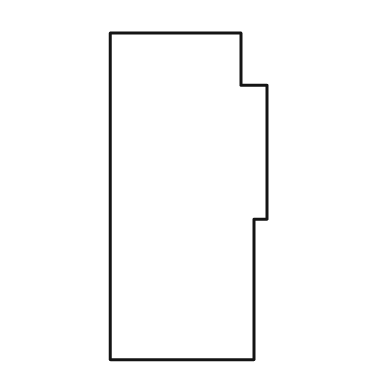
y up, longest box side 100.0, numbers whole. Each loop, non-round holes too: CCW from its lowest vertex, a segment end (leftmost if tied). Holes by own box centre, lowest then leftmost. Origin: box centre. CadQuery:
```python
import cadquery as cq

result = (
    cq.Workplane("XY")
    .moveTo(-24.0, -50.0)
    .lineTo(20.0, -50.0)
    .lineTo(20.0, -7.0)
    .lineTo(24.0, -7.0)
    .lineTo(24.0, 34.0)
    .lineTo(16.0, 34.0)
    .lineTo(16.0, 50.0)
    .lineTo(-24.0, 50.0)
    .close()
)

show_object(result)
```